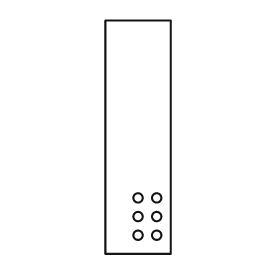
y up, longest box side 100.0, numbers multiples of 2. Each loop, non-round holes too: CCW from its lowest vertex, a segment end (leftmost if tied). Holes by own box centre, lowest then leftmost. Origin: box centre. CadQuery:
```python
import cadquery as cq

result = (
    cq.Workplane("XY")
    .moveTo(-14.0, -50.0)
    .lineTo(14.0, -50.0)
    .lineTo(14.0, 50.0)
    .lineTo(-14.0, 50.0)
    .close()
    .moveTo(0.0, -42.0)
    .circle(2.0)
    .moveTo(8.0, -42.0)
    .circle(2.0)
    .moveTo(0.0, -34.0)
    .circle(2.0)
    .moveTo(8.0, -34.0)
    .circle(2.0)
    .moveTo(0.0, -26.0)
    .circle(2.0)
    .moveTo(8.0, -26.0)
    .circle(2.0)
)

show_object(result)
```